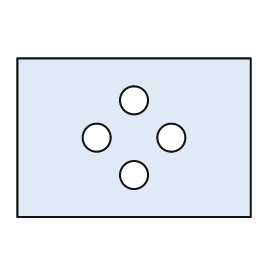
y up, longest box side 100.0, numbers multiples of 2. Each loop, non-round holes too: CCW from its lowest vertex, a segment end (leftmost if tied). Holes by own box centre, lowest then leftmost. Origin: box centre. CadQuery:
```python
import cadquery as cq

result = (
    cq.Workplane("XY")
    .moveTo(-50.0, -34.0)
    .lineTo(50.0, -34.0)
    .lineTo(50.0, 34.0)
    .lineTo(-50.0, 34.0)
    .close()
    .moveTo(0.0, -16.0)
    .circle(6.0)
    .moveTo(-16.0, 0.0)
    .circle(6.0)
    .moveTo(16.0, 0.0)
    .circle(6.0)
    .moveTo(0.0, 16.0)
    .circle(6.0)
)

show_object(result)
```